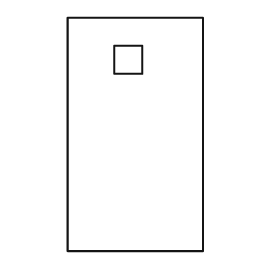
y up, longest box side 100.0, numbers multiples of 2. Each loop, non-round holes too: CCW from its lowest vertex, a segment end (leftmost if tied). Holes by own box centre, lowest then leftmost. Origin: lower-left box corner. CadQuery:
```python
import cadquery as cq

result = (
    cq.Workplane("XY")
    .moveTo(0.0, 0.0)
    .lineTo(58.0, 0.0)
    .lineTo(58.0, 100.0)
    .lineTo(0.0, 100.0)
    .close()
    .moveTo(20.0, 76.0)
    .lineTo(32.0, 76.0)
    .lineTo(32.0, 88.0)
    .lineTo(20.0, 88.0)
    .close()
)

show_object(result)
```